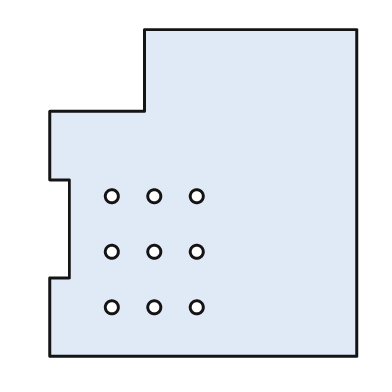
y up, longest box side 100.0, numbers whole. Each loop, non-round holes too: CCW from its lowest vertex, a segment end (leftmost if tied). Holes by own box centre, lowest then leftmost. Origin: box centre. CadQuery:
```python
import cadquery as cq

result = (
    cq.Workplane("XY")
    .moveTo(-47.0, -50.0)
    .lineTo(47.0, -50.0)
    .lineTo(47.0, 50.0)
    .lineTo(-18.0, 50.0)
    .lineTo(-18.0, 25.0)
    .lineTo(-47.0, 25.0)
    .lineTo(-47.0, 4.0)
    .lineTo(-41.0, 4.0)
    .lineTo(-41.0, -26.0)
    .lineTo(-47.0, -26.0)
    .close()
    .moveTo(-28.0, -35.0)
    .circle(2.0)
    .moveTo(-15.0, -35.0)
    .circle(2.0)
    .moveTo(-2.0, -35.0)
    .circle(2.0)
    .moveTo(-28.0, -18.0)
    .circle(2.0)
    .moveTo(-15.0, -18.0)
    .circle(2.0)
    .moveTo(-2.0, -18.0)
    .circle(2.0)
    .moveTo(-28.0, -1.0)
    .circle(2.0)
    .moveTo(-15.0, -1.0)
    .circle(2.0)
    .moveTo(-2.0, -1.0)
    .circle(2.0)
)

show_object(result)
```